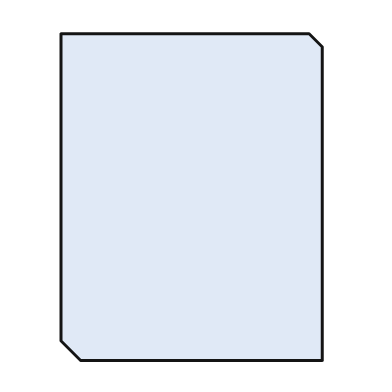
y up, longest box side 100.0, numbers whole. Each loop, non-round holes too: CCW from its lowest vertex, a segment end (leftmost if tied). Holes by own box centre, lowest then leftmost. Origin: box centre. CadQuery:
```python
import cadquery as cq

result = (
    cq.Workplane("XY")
    .moveTo(-34.0, -50.0)
    .lineTo(40.0, -50.0)
    .lineTo(40.0, 46.0)
    .lineTo(36.0, 50.0)
    .lineTo(-40.0, 50.0)
    .lineTo(-40.0, -44.0)
    .close()
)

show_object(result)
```